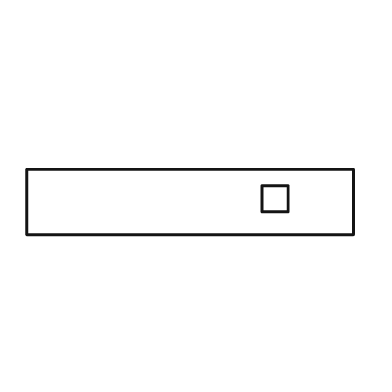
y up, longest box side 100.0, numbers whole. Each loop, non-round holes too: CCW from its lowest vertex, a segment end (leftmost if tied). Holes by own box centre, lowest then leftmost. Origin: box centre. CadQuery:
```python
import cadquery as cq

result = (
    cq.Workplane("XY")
    .moveTo(-50.0, -10.0)
    .lineTo(50.0, -10.0)
    .lineTo(50.0, 10.0)
    .lineTo(-50.0, 10.0)
    .close()
    .moveTo(22.0, -3.0)
    .lineTo(30.0, -3.0)
    .lineTo(30.0, 5.0)
    .lineTo(22.0, 5.0)
    .close()
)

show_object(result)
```